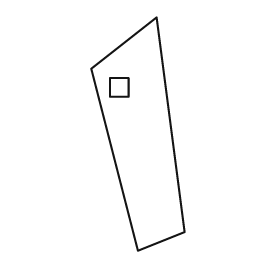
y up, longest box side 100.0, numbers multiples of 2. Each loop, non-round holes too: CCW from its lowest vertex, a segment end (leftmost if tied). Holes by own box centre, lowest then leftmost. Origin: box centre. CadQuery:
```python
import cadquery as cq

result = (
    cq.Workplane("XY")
    .moveTo(0.0, -50.0)
    .lineTo(20.0, -42.0)
    .lineTo(8.0, 50.0)
    .lineTo(-20.0, 28.0)
    .close()
    .moveTo(-12.0, 16.0)
    .lineTo(-4.0, 16.0)
    .lineTo(-4.0, 24.0)
    .lineTo(-12.0, 24.0)
    .close()
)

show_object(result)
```